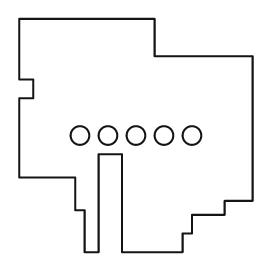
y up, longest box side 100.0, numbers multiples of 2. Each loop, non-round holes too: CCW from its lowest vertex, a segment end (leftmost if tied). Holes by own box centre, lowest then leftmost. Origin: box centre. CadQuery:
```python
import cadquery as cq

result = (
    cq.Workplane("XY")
    .moveTo(-22.0, -50.0)
    .lineTo(-16.0, -50.0)
    .lineTo(-16.0, -8.0)
    .lineTo(-6.0, -8.0)
    .lineTo(-6.0, -50.0)
    .lineTo(20.0, -50.0)
    .lineTo(20.0, -42.0)
    .lineTo(24.0, -42.0)
    .lineTo(24.0, -34.0)
    .lineTo(38.0, -34.0)
    .lineTo(38.0, -28.0)
    .lineTo(50.0, -28.0)
    .lineTo(50.0, 34.0)
    .lineTo(8.0, 34.0)
    .lineTo(8.0, 50.0)
    .lineTo(-50.0, 50.0)
    .lineTo(-50.0, 24.0)
    .lineTo(-44.0, 24.0)
    .lineTo(-44.0, 16.0)
    .lineTo(-50.0, 16.0)
    .lineTo(-50.0, -18.0)
    .lineTo(-26.0, -18.0)
    .lineTo(-26.0, -32.0)
    .lineTo(-22.0, -32.0)
    .close()
    .moveTo(-24.0, 0.0)
    .circle(4.0)
    .moveTo(-12.0, 0.0)
    .circle(4.0)
    .moveTo(0.0, 0.0)
    .circle(4.0)
    .moveTo(12.0, 0.0)
    .circle(4.0)
    .moveTo(24.0, 0.0)
    .circle(4.0)
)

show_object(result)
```